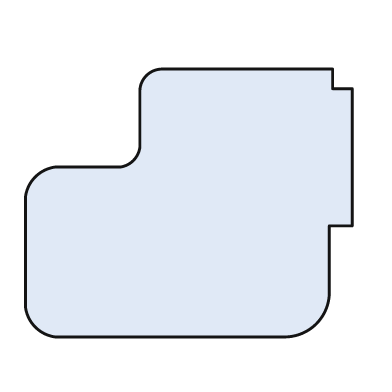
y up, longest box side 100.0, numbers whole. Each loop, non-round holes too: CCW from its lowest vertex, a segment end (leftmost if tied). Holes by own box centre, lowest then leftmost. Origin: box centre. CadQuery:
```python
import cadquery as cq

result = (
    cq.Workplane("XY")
    .moveTo(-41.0, -41.0)
    .lineTo(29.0, -41.0)
    .threePointArc((39.0, -37.0), (43.0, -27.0))
    .lineTo(43.0, -7.0)
    .lineTo(50.0, -7.0)
    .lineTo(50.0, 35.0)
    .lineTo(44.0, 35.0)
    .lineTo(44.0, 41.0)
    .lineTo(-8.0, 41.0)
    .threePointArc((-13.0, 39.0), (-15.0, 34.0))
    .lineTo(-15.0, 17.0)
    .threePointArc((-17.0, 13.0), (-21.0, 11.0))
    .lineTo(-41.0, 11.0)
    .threePointArc((-47.0, 8.0), (-50.0, 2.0))
    .lineTo(-50.0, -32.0)
    .threePointArc((-47.0, -38.0), (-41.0, -41.0))
    .close()
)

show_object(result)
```